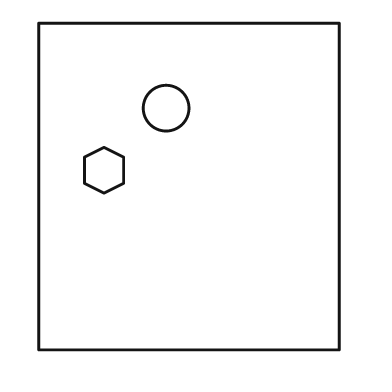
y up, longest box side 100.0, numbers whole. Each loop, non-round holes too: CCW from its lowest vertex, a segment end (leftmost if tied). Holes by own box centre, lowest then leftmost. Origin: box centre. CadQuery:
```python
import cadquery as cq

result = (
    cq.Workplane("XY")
    .moveTo(-46.0, -50.0)
    .lineTo(46.0, -50.0)
    .lineTo(46.0, 50.0)
    .lineTo(-46.0, 50.0)
    .close()
    .moveTo(-26.0, -2.0)
    .lineTo(-20.0, 1.0)
    .lineTo(-20.0, 9.0)
    .lineTo(-26.0, 12.0)
    .lineTo(-32.0, 9.0)
    .lineTo(-32.0, 1.0)
    .close()
    .moveTo(-7.0, 24.0)
    .circle(7.0)
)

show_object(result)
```